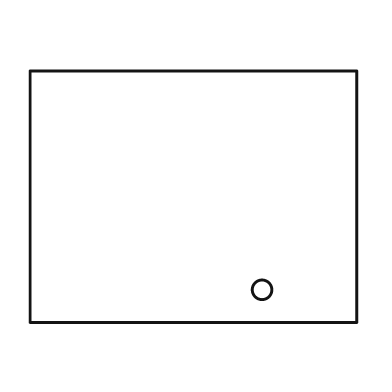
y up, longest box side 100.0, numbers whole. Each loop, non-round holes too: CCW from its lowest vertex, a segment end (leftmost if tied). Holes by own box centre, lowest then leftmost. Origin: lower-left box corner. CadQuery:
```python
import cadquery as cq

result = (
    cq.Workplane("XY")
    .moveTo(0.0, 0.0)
    .lineTo(100.0, 0.0)
    .lineTo(100.0, 77.0)
    .lineTo(0.0, 77.0)
    .close()
    .moveTo(71.0, 10.0)
    .circle(3.0)
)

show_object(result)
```